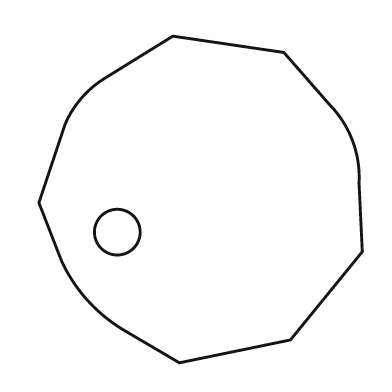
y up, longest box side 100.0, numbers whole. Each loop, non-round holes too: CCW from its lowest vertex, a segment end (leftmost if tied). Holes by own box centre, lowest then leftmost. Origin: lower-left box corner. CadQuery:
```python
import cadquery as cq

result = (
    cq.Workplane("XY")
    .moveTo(43.0, 0.0)
    .lineTo(77.0, 7.0)
    .lineTo(99.0, 34.0)
    .lineTo(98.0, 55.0)
    .threePointArc((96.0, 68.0), (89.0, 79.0))
    .lineTo(75.0, 95.0)
    .lineTo(41.0, 100.0)
    .lineTo(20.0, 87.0)
    .threePointArc((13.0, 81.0), (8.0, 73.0))
    .lineTo(0.0, 49.0)
    .lineTo(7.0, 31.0)
    .threePointArc((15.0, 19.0), (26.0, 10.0))
    .close()
    .moveTo(24.0, 40.0)
    .circle(7.0)
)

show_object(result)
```